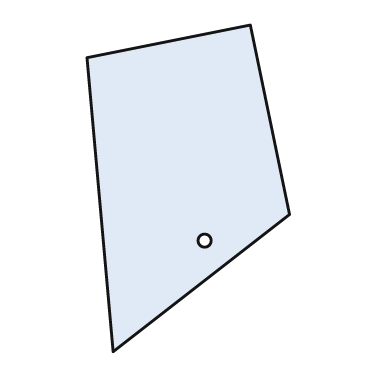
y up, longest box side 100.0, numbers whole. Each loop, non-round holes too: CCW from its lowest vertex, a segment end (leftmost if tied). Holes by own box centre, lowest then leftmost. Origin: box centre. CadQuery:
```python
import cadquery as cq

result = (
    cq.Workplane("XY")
    .moveTo(-23.0, -50.0)
    .lineTo(31.0, -8.0)
    .lineTo(19.0, 50.0)
    .lineTo(-31.0, 40.0)
    .close()
    .moveTo(5.0, -16.0)
    .circle(2.0)
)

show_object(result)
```